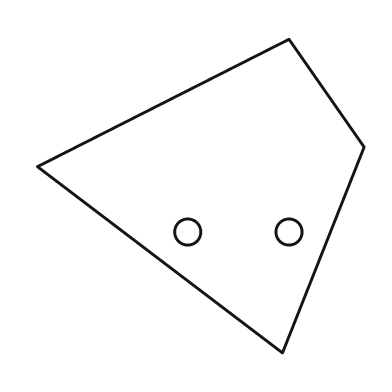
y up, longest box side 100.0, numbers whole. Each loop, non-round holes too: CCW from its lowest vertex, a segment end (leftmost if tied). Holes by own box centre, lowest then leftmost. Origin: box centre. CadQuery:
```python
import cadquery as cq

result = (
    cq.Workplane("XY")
    .moveTo(25.0, -48.0)
    .lineTo(50.0, 15.0)
    .lineTo(27.0, 48.0)
    .lineTo(-50.0, 9.0)
    .close()
    .moveTo(-4.0, -11.0)
    .circle(4.0)
    .moveTo(27.0, -11.0)
    .circle(4.0)
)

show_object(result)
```